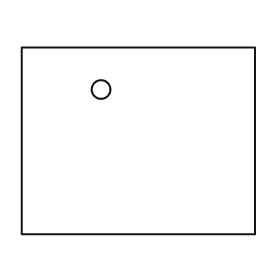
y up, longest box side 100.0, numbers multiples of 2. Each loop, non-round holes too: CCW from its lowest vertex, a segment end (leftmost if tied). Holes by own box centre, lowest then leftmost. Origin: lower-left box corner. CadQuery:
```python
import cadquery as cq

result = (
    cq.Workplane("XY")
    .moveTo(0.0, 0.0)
    .lineTo(100.0, 0.0)
    .lineTo(100.0, 80.0)
    .lineTo(0.0, 80.0)
    .close()
    .moveTo(34.0, 62.0)
    .circle(4.0)
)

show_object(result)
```